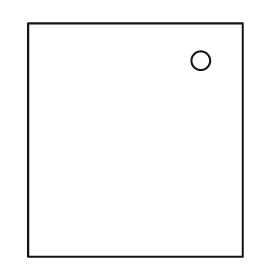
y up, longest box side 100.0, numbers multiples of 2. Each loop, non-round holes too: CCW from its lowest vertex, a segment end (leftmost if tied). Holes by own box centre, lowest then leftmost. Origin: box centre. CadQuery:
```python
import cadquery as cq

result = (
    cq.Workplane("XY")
    .moveTo(-46.0, -50.0)
    .lineTo(46.0, -50.0)
    .lineTo(46.0, 50.0)
    .lineTo(-46.0, 50.0)
    .close()
    .moveTo(28.0, 34.0)
    .circle(4.0)
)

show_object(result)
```